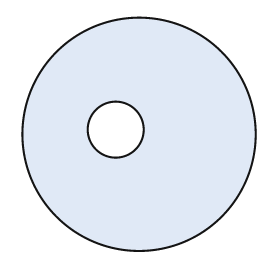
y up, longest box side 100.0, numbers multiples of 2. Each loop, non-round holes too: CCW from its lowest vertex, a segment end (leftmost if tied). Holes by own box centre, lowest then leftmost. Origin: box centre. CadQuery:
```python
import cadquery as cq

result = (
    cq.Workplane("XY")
    .moveTo(0.0, 0.0)
    .circle(50.0)
    .moveTo(-10.0, 2.0)
    .circle(12.0)
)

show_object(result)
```